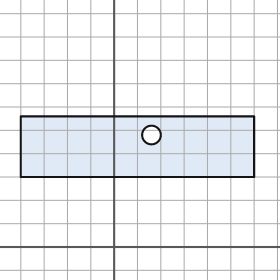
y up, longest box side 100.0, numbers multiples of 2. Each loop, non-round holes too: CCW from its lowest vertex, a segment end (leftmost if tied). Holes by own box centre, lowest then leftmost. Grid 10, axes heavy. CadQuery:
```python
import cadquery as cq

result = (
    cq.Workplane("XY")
    .moveTo(-40.0, 30.0)
    .lineTo(60.0, 30.0)
    .lineTo(60.0, 56.0)
    .lineTo(-40.0, 56.0)
    .close()
    .moveTo(16.0, 48.0)
    .circle(4.0)
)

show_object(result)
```